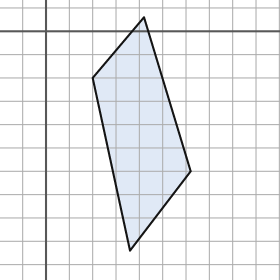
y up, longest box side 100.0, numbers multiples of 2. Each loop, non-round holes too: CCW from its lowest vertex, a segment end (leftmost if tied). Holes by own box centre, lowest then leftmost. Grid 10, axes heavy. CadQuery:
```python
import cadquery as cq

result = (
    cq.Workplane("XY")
    .moveTo(36.0, -94.0)
    .lineTo(62.0, -60.0)
    .lineTo(42.0, 6.0)
    .lineTo(20.0, -20.0)
    .close()
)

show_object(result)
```